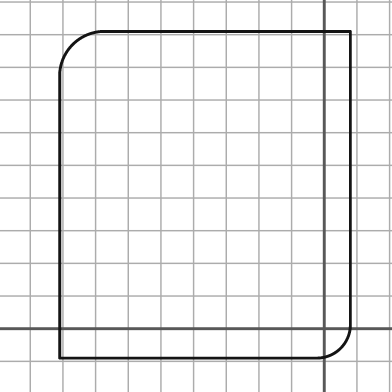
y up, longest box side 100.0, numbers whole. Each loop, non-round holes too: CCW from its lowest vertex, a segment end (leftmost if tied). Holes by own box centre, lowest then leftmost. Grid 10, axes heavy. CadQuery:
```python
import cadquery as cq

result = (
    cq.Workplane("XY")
    .moveTo(-81.0, -9.0)
    .lineTo(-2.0, -9.0)
    .threePointArc((5.0, -6.0), (8.0, 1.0))
    .lineTo(8.0, 91.0)
    .lineTo(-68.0, 91.0)
    .threePointArc((-77.0, 87.0), (-81.0, 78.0))
    .close()
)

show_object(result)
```